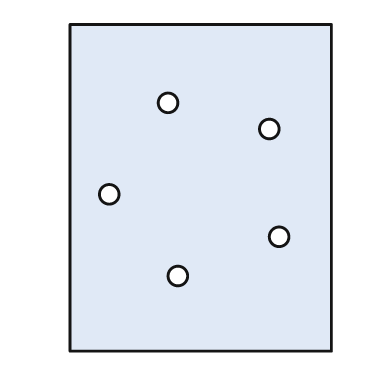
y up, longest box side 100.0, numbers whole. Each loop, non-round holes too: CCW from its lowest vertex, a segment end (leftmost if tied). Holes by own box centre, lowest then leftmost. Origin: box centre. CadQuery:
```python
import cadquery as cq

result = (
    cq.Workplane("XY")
    .moveTo(-40.0, -50.0)
    .lineTo(40.0, -50.0)
    .lineTo(40.0, 50.0)
    .lineTo(-40.0, 50.0)
    .close()
    .moveTo(-7.0, -27.0)
    .circle(3.0)
    .moveTo(24.0, -15.0)
    .circle(3.0)
    .moveTo(-28.0, -2.0)
    .circle(3.0)
    .moveTo(21.0, 18.0)
    .circle(3.0)
    .moveTo(-10.0, 26.0)
    .circle(3.0)
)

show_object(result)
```